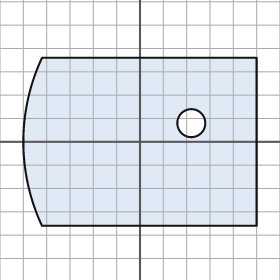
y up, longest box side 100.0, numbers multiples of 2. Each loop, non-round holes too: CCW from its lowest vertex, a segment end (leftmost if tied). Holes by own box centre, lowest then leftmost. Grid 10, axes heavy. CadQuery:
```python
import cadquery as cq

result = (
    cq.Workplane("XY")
    .moveTo(-42.0, -36.0)
    .lineTo(50.0, -36.0)
    .lineTo(50.0, 36.0)
    .lineTo(-42.0, 36.0)
    .threePointArc((-50.0, 0.0), (-42.0, -36.0))
    .close()
    .moveTo(22.0, 8.0)
    .circle(6.0)
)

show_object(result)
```